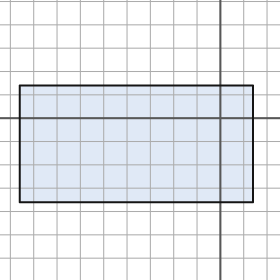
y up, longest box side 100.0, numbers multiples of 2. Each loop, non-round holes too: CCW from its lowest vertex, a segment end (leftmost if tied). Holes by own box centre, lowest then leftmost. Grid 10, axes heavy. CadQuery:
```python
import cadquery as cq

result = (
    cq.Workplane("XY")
    .moveTo(-86.0, -36.0)
    .lineTo(14.0, -36.0)
    .lineTo(14.0, 14.0)
    .lineTo(-86.0, 14.0)
    .close()
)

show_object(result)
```